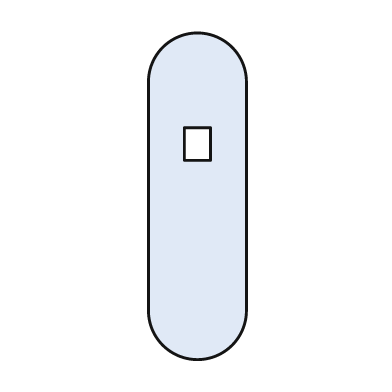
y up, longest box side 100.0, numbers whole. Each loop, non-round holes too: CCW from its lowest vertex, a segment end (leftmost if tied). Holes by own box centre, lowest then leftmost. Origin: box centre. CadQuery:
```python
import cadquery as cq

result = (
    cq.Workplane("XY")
    .moveTo(-15.0, -35.0)
    .threePointArc((0.0, -50.0), (15.0, -35.0))
    .lineTo(15.0, 35.0)
    .threePointArc((0.0, 50.0), (-15.0, 35.0))
    .close()
    .moveTo(-4.0, 11.0)
    .lineTo(4.0, 11.0)
    .lineTo(4.0, 21.0)
    .lineTo(-4.0, 21.0)
    .close()
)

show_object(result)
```